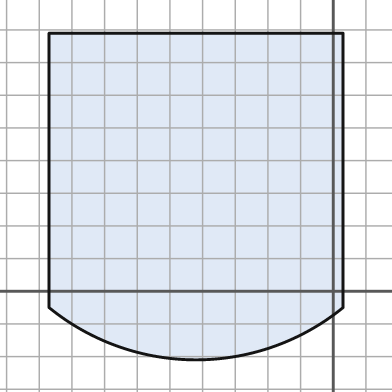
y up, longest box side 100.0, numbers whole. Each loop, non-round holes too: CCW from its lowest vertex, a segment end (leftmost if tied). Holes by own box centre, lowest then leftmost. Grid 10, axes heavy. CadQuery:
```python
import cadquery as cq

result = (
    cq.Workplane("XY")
    .moveTo(-87.0, -5.0)
    .threePointArc((-42.0, -21.0), (3.0, -5.0))
    .lineTo(3.0, 79.0)
    .lineTo(-87.0, 79.0)
    .close()
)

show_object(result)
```